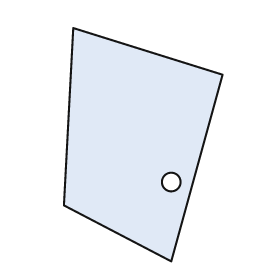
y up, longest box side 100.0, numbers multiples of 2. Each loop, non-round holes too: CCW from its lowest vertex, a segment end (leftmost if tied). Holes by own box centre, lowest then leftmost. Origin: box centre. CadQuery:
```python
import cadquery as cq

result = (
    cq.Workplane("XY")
    .moveTo(12.0, -50.0)
    .lineTo(34.0, 30.0)
    .lineTo(-30.0, 50.0)
    .lineTo(-34.0, -26.0)
    .close()
    .moveTo(12.0, -16.0)
    .circle(4.0)
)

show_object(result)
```